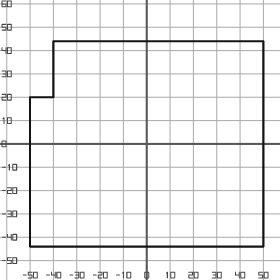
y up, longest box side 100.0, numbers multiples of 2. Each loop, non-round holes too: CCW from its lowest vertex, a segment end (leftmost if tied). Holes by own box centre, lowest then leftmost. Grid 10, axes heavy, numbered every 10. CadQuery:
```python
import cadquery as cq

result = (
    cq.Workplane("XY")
    .moveTo(-50.0, -44.0)
    .lineTo(50.0, -44.0)
    .lineTo(50.0, 44.0)
    .lineTo(-40.0, 44.0)
    .lineTo(-40.0, 20.0)
    .lineTo(-50.0, 20.0)
    .close()
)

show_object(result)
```